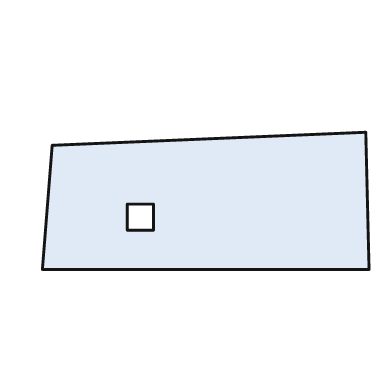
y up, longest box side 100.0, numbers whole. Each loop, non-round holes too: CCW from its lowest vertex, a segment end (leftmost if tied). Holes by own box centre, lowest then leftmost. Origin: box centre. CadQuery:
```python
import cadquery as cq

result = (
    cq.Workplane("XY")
    .moveTo(-50.0, -21.0)
    .lineTo(50.0, -21.0)
    .lineTo(49.0, 21.0)
    .lineTo(-47.0, 17.0)
    .close()
    .moveTo(-24.0, -9.0)
    .lineTo(-16.0, -9.0)
    .lineTo(-16.0, -1.0)
    .lineTo(-24.0, -1.0)
    .close()
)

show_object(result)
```